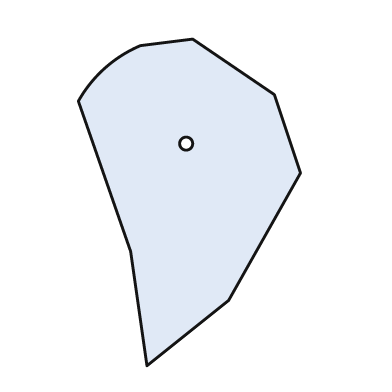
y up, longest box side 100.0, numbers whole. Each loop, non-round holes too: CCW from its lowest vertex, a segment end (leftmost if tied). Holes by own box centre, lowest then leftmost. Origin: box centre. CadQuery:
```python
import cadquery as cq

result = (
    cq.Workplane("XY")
    .moveTo(-13.0, -50.0)
    .lineTo(12.0, -30.0)
    .lineTo(34.0, 9.0)
    .lineTo(26.0, 33.0)
    .lineTo(1.0, 50.0)
    .lineTo(-15.0, 48.0)
    .threePointArc((-26.0, 41.0), (-34.0, 31.0))
    .lineTo(-18.0, -15.0)
    .close()
    .moveTo(-1.0, 18.0)
    .circle(2.0)
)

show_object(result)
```